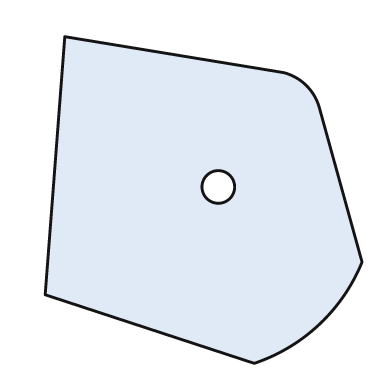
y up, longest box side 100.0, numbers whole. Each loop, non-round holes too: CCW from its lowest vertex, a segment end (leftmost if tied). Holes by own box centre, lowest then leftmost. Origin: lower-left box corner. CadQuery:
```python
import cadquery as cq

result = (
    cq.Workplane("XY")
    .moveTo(64.0, 0.0)
    .threePointArc((84.0, 12.0), (97.0, 31.0))
    .lineTo(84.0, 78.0)
    .threePointArc((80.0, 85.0), (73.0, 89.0))
    .lineTo(6.0, 100.0)
    .lineTo(0.0, 21.0)
    .close()
    .moveTo(53.0, 54.0)
    .circle(5.0)
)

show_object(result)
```